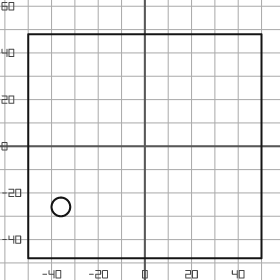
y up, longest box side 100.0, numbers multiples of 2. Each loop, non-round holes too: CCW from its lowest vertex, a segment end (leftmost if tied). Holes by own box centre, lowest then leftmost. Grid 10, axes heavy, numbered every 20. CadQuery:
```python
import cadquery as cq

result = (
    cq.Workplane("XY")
    .moveTo(-50.0, -48.0)
    .lineTo(50.0, -48.0)
    .lineTo(50.0, 48.0)
    .lineTo(-50.0, 48.0)
    .close()
    .moveTo(-36.0, -26.0)
    .circle(4.0)
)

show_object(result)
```